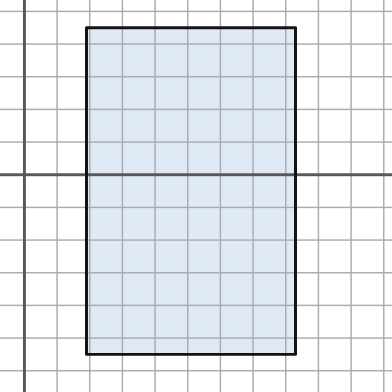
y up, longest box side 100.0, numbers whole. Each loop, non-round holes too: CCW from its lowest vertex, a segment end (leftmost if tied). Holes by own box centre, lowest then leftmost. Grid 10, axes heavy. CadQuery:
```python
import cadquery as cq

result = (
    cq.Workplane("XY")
    .moveTo(19.0, -55.0)
    .lineTo(83.0, -55.0)
    .lineTo(83.0, 45.0)
    .lineTo(19.0, 45.0)
    .close()
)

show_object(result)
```